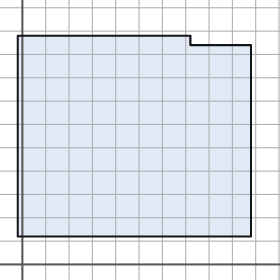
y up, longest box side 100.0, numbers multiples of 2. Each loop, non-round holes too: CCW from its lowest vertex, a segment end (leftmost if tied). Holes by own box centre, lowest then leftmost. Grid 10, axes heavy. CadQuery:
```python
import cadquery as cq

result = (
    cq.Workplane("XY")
    .moveTo(-2.0, 12.0)
    .lineTo(98.0, 12.0)
    .lineTo(98.0, 94.0)
    .lineTo(72.0, 94.0)
    .lineTo(72.0, 98.0)
    .lineTo(-2.0, 98.0)
    .close()
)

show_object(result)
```